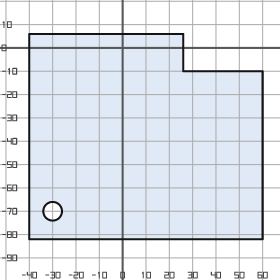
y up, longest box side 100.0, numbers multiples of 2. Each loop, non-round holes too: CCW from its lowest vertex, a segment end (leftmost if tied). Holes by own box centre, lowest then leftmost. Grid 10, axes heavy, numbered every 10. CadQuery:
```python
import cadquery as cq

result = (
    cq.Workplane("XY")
    .moveTo(-40.0, -82.0)
    .lineTo(60.0, -82.0)
    .lineTo(60.0, -10.0)
    .lineTo(26.0, -10.0)
    .lineTo(26.0, 6.0)
    .lineTo(-40.0, 6.0)
    .close()
    .moveTo(-30.0, -70.0)
    .circle(4.0)
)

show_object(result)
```